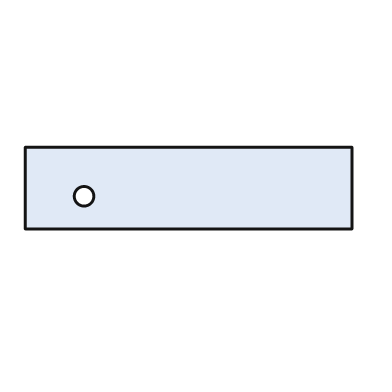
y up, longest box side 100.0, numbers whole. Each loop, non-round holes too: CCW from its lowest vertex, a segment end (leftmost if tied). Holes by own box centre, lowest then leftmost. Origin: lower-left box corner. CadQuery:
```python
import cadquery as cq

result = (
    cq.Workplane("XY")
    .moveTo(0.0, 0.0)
    .lineTo(100.0, 0.0)
    .lineTo(100.0, 25.0)
    .lineTo(0.0, 25.0)
    .close()
    .moveTo(18.0, 10.0)
    .circle(3.0)
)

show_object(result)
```